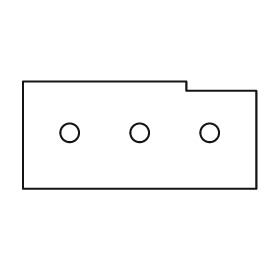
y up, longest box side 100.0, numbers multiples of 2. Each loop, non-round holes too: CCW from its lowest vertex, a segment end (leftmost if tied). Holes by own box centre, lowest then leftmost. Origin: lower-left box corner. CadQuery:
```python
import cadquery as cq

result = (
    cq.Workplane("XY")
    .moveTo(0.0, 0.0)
    .lineTo(100.0, 0.0)
    .lineTo(100.0, 42.0)
    .lineTo(70.0, 42.0)
    .lineTo(70.0, 46.0)
    .lineTo(0.0, 46.0)
    .close()
    .moveTo(20.0, 24.0)
    .circle(4.0)
    .moveTo(50.0, 24.0)
    .circle(4.0)
    .moveTo(80.0, 24.0)
    .circle(4.0)
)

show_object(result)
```